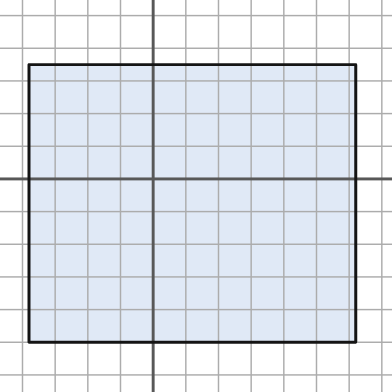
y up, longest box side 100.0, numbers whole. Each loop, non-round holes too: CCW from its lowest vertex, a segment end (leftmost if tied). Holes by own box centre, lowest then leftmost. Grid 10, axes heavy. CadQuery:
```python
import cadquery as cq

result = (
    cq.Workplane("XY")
    .moveTo(-38.0, -50.0)
    .lineTo(62.0, -50.0)
    .lineTo(62.0, 35.0)
    .lineTo(-38.0, 35.0)
    .close()
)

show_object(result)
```